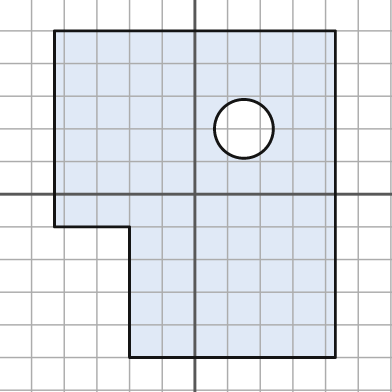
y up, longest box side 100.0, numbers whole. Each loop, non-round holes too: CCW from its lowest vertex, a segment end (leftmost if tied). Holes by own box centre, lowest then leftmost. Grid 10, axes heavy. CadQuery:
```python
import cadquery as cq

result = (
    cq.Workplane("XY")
    .moveTo(-20.0, -50.0)
    .lineTo(43.0, -50.0)
    .lineTo(43.0, 50.0)
    .lineTo(-43.0, 50.0)
    .lineTo(-43.0, -10.0)
    .lineTo(-20.0, -10.0)
    .close()
    .moveTo(15.0, 20.0)
    .circle(9.0)
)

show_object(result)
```